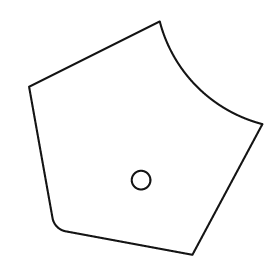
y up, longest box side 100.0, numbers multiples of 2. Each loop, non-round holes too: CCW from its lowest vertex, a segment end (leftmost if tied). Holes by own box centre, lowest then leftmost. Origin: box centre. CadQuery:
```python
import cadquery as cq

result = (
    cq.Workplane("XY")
    .moveTo(20.0, -50.0)
    .lineTo(50.0, 6.0)
    .threePointArc((22.0, 22.0), (6.0, 50.0))
    .lineTo(-50.0, 22.0)
    .lineTo(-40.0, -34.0)
    .threePointArc((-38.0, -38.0), (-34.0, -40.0))
    .close()
    .moveTo(-2.0, -18.0)
    .circle(4.0)
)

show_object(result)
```